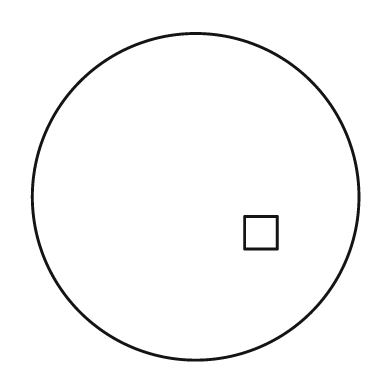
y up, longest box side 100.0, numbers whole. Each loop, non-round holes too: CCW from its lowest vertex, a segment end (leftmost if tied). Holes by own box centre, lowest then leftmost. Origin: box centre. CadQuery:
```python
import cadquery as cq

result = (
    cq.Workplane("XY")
    .moveTo(0.0, 0.0)
    .circle(50.0)
    .moveTo(15.0, -16.0)
    .lineTo(25.0, -16.0)
    .lineTo(25.0, -6.0)
    .lineTo(15.0, -6.0)
    .close()
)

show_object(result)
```